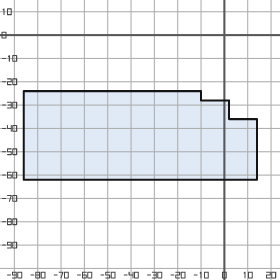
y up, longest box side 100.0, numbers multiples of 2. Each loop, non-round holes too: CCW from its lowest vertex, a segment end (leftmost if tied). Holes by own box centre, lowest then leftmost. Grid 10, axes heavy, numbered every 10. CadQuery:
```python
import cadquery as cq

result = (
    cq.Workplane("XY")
    .moveTo(-86.0, -62.0)
    .lineTo(14.0, -62.0)
    .lineTo(14.0, -36.0)
    .lineTo(2.0, -36.0)
    .lineTo(2.0, -28.0)
    .lineTo(-10.0, -28.0)
    .lineTo(-10.0, -24.0)
    .lineTo(-86.0, -24.0)
    .close()
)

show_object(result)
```